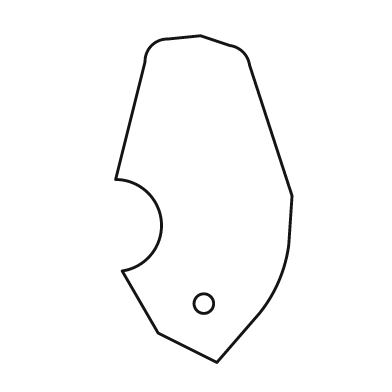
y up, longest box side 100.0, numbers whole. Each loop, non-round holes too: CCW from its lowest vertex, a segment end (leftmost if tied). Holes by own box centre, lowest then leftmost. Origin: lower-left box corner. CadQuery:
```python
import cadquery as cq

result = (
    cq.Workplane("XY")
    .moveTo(31.0, 0.0)
    .lineTo(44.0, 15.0)
    .threePointArc((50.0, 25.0), (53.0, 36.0))
    .lineTo(54.0, 51.0)
    .lineTo(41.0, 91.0)
    .threePointArc((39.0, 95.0), (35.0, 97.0))
    .lineTo(26.0, 100.0)
    .lineTo(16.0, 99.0)
    .threePointArc((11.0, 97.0), (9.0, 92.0))
    .lineTo(0.0, 56.0)
    .threePointArc((14.0, 43.0), (2.0, 28.0))
    .lineTo(13.0, 9.0)
    .close()
    .moveTo(27.0, 18.0)
    .circle(3.0)
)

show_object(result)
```